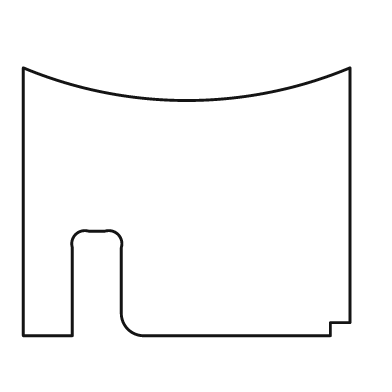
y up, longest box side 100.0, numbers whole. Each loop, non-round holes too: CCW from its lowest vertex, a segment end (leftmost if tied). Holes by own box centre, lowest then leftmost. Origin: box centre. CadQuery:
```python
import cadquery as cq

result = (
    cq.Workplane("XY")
    .moveTo(-50.0, -41.0)
    .lineTo(-35.0, -41.0)
    .lineTo(-35.0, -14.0)
    .threePointArc((-34.0, -10.0), (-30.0, -9.0))
    .lineTo(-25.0, -9.0)
    .threePointArc((-21.0, -10.0), (-20.0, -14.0))
    .lineTo(-20.0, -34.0)
    .threePointArc((-18.0, -39.0), (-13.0, -41.0))
    .lineTo(44.0, -41.0)
    .lineTo(44.0, -37.0)
    .lineTo(50.0, -37.0)
    .lineTo(50.0, 41.0)
    .threePointArc((0.0, 31.0), (-50.0, 41.0))
    .close()
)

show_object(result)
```